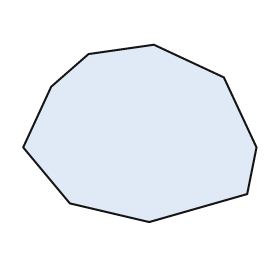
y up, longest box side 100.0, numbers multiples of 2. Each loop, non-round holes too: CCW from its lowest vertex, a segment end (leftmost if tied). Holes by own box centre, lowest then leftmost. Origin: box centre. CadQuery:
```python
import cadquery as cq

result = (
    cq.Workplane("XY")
    .moveTo(4.0, -38.0)
    .lineTo(46.0, -26.0)
    .lineTo(50.0, -6.0)
    .lineTo(36.0, 24.0)
    .lineTo(6.0, 38.0)
    .lineTo(-22.0, 34.0)
    .lineTo(-38.0, 20.0)
    .lineTo(-50.0, -6.0)
    .lineTo(-30.0, -30.0)
    .close()
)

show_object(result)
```